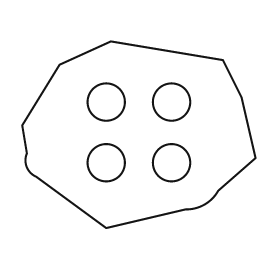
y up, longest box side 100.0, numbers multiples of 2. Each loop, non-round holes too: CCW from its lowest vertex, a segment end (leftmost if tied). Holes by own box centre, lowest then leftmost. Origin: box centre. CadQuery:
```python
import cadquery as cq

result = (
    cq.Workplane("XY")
    .moveTo(-14.0, -40.0)
    .lineTo(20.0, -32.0)
    .threePointArc((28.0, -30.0), (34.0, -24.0))
    .lineTo(50.0, -10.0)
    .lineTo(44.0, 16.0)
    .lineTo(36.0, 32.0)
    .lineTo(-12.0, 40.0)
    .lineTo(-34.0, 30.0)
    .lineTo(-50.0, 4.0)
    .lineTo(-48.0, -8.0)
    .threePointArc((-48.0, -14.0), (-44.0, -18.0))
    .close()
    .moveTo(-14.0, -12.0)
    .circle(8.0)
    .moveTo(14.0, -12.0)
    .circle(8.0)
    .moveTo(-14.0, 14.0)
    .circle(8.0)
    .moveTo(14.0, 14.0)
    .circle(8.0)
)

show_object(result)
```